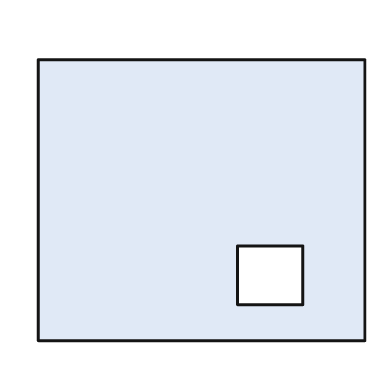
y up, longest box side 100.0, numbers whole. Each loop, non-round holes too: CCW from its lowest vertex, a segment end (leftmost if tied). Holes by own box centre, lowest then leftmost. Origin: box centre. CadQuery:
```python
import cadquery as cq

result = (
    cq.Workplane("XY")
    .moveTo(-50.0, -43.0)
    .lineTo(50.0, -43.0)
    .lineTo(50.0, 43.0)
    .lineTo(-50.0, 43.0)
    .close()
    .moveTo(11.0, -32.0)
    .lineTo(31.0, -32.0)
    .lineTo(31.0, -14.0)
    .lineTo(11.0, -14.0)
    .close()
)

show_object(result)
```